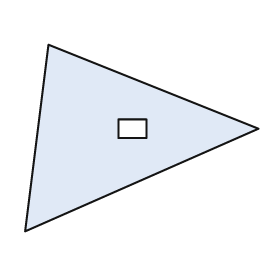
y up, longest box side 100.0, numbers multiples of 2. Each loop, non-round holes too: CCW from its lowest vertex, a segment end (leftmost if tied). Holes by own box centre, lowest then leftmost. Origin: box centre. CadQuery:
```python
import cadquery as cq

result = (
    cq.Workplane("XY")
    .moveTo(-50.0, -40.0)
    .lineTo(50.0, 4.0)
    .lineTo(-40.0, 40.0)
    .close()
    .moveTo(-10.0, 0.0)
    .lineTo(2.0, 0.0)
    .lineTo(2.0, 8.0)
    .lineTo(-10.0, 8.0)
    .close()
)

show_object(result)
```